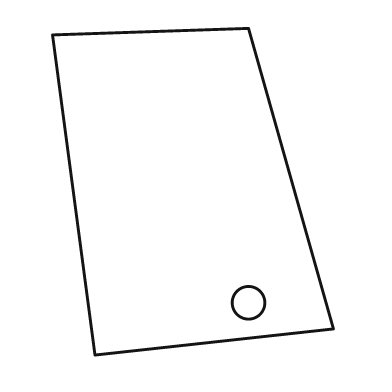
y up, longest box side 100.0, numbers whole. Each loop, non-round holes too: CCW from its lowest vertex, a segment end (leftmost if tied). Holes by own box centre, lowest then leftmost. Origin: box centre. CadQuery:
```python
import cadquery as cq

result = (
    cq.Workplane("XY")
    .moveTo(-30.0, -50.0)
    .lineTo(43.0, -42.0)
    .lineTo(17.0, 50.0)
    .lineTo(-43.0, 48.0)
    .close()
    .moveTo(17.0, -34.0)
    .circle(5.0)
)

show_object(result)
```